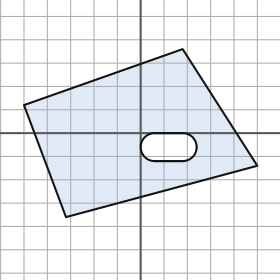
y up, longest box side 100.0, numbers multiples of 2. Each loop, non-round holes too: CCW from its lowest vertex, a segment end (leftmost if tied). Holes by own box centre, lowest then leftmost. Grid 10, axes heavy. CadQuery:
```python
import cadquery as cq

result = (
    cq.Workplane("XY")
    .moveTo(-32.0, -36.0)
    .lineTo(50.0, -14.0)
    .lineTo(18.0, 36.0)
    .lineTo(-50.0, 12.0)
    .close()
    .moveTo(6.0, -12.0)
    .lineTo(18.0, -12.0)
    .threePointArc((24.0, -6.0), (18.0, 0.0))
    .lineTo(6.0, 0.0)
    .threePointArc((0.0, -6.0), (6.0, -12.0))
    .close()
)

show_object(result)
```